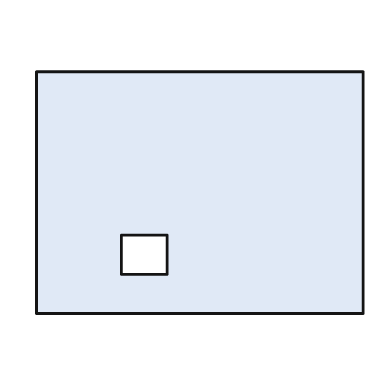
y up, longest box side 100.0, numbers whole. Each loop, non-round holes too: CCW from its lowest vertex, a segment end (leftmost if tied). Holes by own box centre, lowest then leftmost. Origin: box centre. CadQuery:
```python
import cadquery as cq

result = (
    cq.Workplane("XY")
    .moveTo(-50.0, -37.0)
    .lineTo(50.0, -37.0)
    .lineTo(50.0, 37.0)
    .lineTo(-50.0, 37.0)
    .close()
    .moveTo(-24.0, -25.0)
    .lineTo(-10.0, -25.0)
    .lineTo(-10.0, -13.0)
    .lineTo(-24.0, -13.0)
    .close()
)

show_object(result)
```